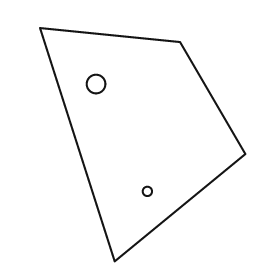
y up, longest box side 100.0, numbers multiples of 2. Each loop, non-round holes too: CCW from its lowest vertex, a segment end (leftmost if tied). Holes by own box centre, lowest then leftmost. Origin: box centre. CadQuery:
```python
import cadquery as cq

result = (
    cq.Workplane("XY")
    .moveTo(-12.0, -50.0)
    .lineTo(44.0, -4.0)
    .lineTo(16.0, 44.0)
    .lineTo(-44.0, 50.0)
    .close()
    .moveTo(2.0, -20.0)
    .circle(2.0)
    .moveTo(-20.0, 26.0)
    .circle(4.0)
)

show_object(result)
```